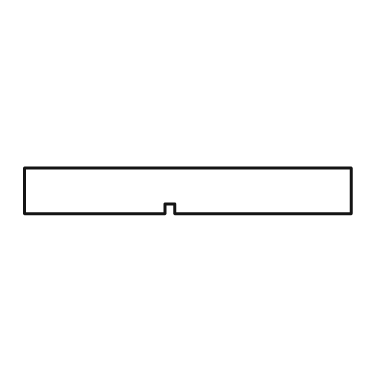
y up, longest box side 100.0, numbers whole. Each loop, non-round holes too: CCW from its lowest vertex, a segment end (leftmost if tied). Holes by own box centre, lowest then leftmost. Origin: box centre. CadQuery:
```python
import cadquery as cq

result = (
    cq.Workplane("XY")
    .moveTo(-50.0, -7.0)
    .lineTo(-7.0, -7.0)
    .lineTo(-7.0, -4.0)
    .lineTo(-4.0, -4.0)
    .lineTo(-4.0, -7.0)
    .lineTo(50.0, -7.0)
    .lineTo(50.0, 7.0)
    .lineTo(-50.0, 7.0)
    .close()
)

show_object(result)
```